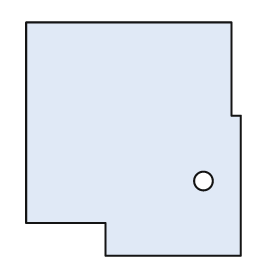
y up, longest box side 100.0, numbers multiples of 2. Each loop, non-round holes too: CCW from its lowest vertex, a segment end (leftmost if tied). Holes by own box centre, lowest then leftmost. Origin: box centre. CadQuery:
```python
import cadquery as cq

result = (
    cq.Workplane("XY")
    .moveTo(-12.0, -50.0)
    .lineTo(46.0, -50.0)
    .lineTo(46.0, 10.0)
    .lineTo(42.0, 10.0)
    .lineTo(42.0, 50.0)
    .lineTo(-46.0, 50.0)
    .lineTo(-46.0, -36.0)
    .lineTo(-12.0, -36.0)
    .close()
    .moveTo(30.0, -18.0)
    .circle(4.0)
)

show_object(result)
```